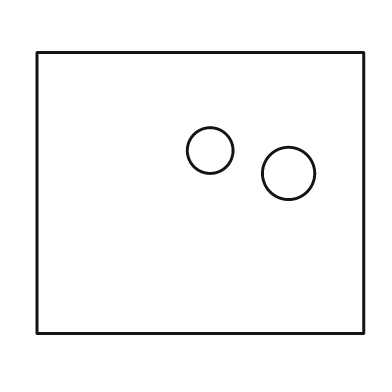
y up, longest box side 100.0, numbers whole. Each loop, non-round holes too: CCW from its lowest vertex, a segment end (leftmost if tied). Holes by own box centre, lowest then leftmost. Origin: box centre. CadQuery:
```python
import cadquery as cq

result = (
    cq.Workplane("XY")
    .moveTo(-50.0, -43.0)
    .lineTo(50.0, -43.0)
    .lineTo(50.0, 43.0)
    .lineTo(-50.0, 43.0)
    .close()
    .moveTo(27.0, 6.0)
    .circle(8.0)
    .moveTo(3.0, 13.0)
    .circle(7.0)
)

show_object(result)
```